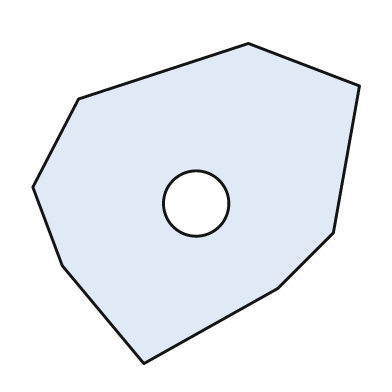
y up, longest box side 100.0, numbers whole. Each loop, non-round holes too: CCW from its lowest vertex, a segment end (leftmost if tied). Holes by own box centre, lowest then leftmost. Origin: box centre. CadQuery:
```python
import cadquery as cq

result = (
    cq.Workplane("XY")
    .moveTo(-16.0, -49.0)
    .lineTo(25.0, -26.0)
    .lineTo(42.0, -9.0)
    .lineTo(50.0, 36.0)
    .lineTo(16.0, 49.0)
    .lineTo(-36.0, 32.0)
    .lineTo(-50.0, 5.0)
    .lineTo(-41.0, -19.0)
    .close()
    .moveTo(0.0, 0.0)
    .circle(10.0)
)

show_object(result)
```